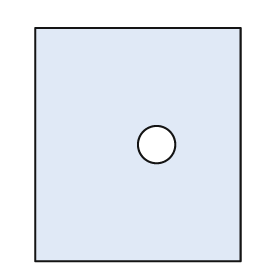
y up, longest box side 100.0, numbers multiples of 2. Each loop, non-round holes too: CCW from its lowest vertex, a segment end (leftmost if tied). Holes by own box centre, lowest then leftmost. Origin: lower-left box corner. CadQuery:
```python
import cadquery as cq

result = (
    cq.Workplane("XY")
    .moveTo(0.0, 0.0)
    .lineTo(88.0, 0.0)
    .lineTo(88.0, 100.0)
    .lineTo(0.0, 100.0)
    .close()
    .moveTo(52.0, 50.0)
    .circle(8.0)
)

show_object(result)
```